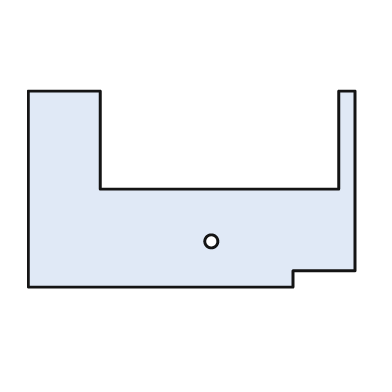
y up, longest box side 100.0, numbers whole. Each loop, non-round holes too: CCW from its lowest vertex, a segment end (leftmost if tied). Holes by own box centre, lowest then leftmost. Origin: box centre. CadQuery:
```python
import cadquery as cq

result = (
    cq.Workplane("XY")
    .moveTo(-50.0, -30.0)
    .lineTo(31.0, -30.0)
    .lineTo(31.0, -25.0)
    .lineTo(50.0, -25.0)
    .lineTo(50.0, 30.0)
    .lineTo(45.0, 30.0)
    .lineTo(45.0, 0.0)
    .lineTo(-28.0, 0.0)
    .lineTo(-28.0, 30.0)
    .lineTo(-50.0, 30.0)
    .close()
    .moveTo(6.0, -16.0)
    .circle(2.0)
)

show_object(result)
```